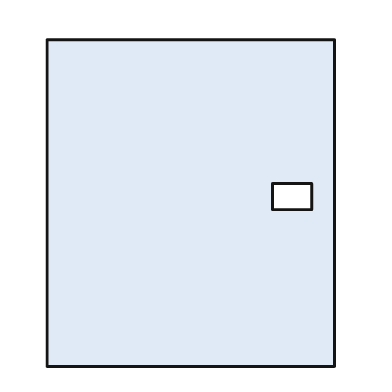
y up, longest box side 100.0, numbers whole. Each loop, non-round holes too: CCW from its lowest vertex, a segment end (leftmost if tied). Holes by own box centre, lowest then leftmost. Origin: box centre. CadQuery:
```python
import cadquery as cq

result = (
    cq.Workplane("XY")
    .moveTo(-44.0, -50.0)
    .lineTo(44.0, -50.0)
    .lineTo(44.0, 50.0)
    .lineTo(-44.0, 50.0)
    .close()
    .moveTo(25.0, -2.0)
    .lineTo(37.0, -2.0)
    .lineTo(37.0, 6.0)
    .lineTo(25.0, 6.0)
    .close()
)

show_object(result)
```